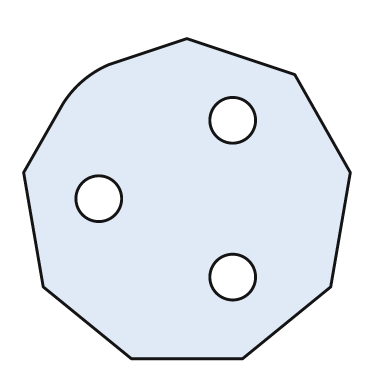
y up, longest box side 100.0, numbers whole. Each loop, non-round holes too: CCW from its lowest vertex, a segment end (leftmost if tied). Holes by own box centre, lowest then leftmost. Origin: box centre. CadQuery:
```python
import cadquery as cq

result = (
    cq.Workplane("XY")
    .moveTo(-17.0, -49.0)
    .lineTo(17.0, -49.0)
    .lineTo(44.0, -27.0)
    .lineTo(50.0, 8.0)
    .lineTo(33.0, 38.0)
    .lineTo(0.0, 49.0)
    .lineTo(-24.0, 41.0)
    .threePointArc((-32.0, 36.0), (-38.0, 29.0))
    .lineTo(-50.0, 8.0)
    .lineTo(-44.0, -27.0)
    .close()
    .moveTo(14.0, -24.0)
    .circle(7.0)
    .moveTo(-27.0, 0.0)
    .circle(7.0)
    .moveTo(14.0, 24.0)
    .circle(7.0)
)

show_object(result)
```